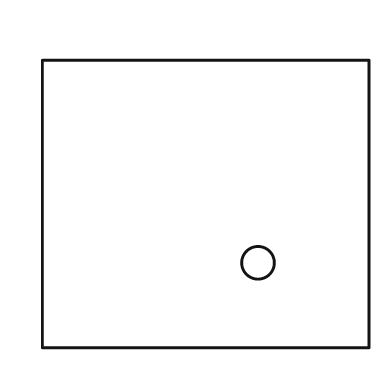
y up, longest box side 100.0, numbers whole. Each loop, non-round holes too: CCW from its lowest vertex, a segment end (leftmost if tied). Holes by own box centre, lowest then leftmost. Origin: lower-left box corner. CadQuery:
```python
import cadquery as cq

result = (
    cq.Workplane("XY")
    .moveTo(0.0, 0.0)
    .lineTo(100.0, 0.0)
    .lineTo(100.0, 88.0)
    .lineTo(0.0, 88.0)
    .close()
    .moveTo(66.0, 26.0)
    .circle(5.0)
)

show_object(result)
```